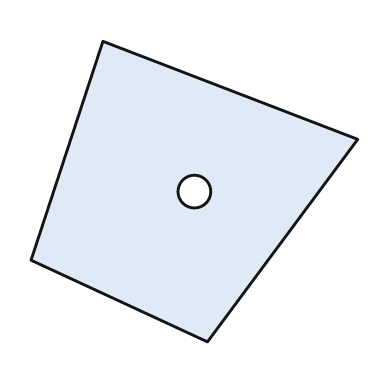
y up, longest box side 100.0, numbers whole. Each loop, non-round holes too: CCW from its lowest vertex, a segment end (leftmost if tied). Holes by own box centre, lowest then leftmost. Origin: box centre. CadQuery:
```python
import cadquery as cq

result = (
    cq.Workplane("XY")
    .moveTo(4.0, -46.0)
    .lineTo(50.0, 16.0)
    .lineTo(-28.0, 46.0)
    .lineTo(-50.0, -21.0)
    .close()
    .moveTo(0.0, 0.0)
    .circle(5.0)
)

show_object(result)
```